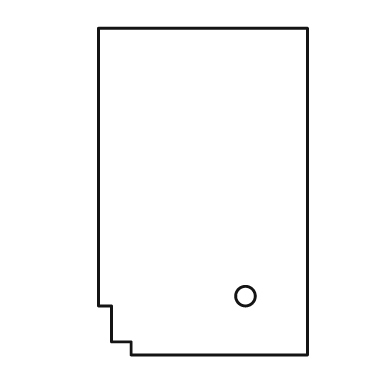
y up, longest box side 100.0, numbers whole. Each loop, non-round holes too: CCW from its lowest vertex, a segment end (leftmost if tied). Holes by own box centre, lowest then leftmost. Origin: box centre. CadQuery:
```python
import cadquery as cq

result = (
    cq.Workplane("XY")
    .moveTo(-22.0, -50.0)
    .lineTo(32.0, -50.0)
    .lineTo(32.0, 50.0)
    .lineTo(-32.0, 50.0)
    .lineTo(-32.0, -35.0)
    .lineTo(-28.0, -35.0)
    .lineTo(-28.0, -46.0)
    .lineTo(-22.0, -46.0)
    .close()
    .moveTo(13.0, -32.0)
    .circle(3.0)
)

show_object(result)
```